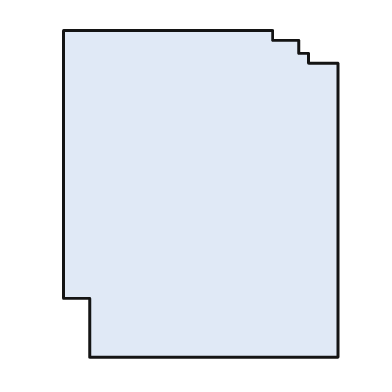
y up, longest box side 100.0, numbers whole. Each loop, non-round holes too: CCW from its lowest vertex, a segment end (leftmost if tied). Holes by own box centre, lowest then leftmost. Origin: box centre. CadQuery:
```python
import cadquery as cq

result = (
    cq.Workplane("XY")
    .moveTo(-34.0, -50.0)
    .lineTo(42.0, -50.0)
    .lineTo(42.0, 40.0)
    .lineTo(33.0, 40.0)
    .lineTo(33.0, 43.0)
    .lineTo(30.0, 43.0)
    .lineTo(30.0, 47.0)
    .lineTo(22.0, 47.0)
    .lineTo(22.0, 50.0)
    .lineTo(-42.0, 50.0)
    .lineTo(-42.0, -32.0)
    .lineTo(-34.0, -32.0)
    .close()
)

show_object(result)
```